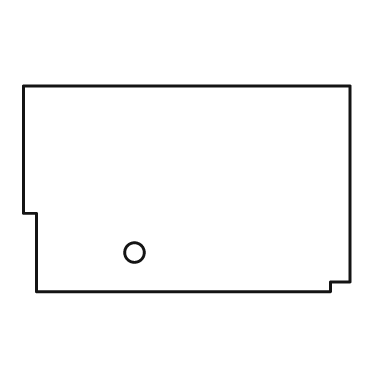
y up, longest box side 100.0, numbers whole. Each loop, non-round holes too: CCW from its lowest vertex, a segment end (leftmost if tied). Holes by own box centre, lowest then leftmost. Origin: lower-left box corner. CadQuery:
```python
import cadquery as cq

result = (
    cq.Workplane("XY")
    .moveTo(4.0, 0.0)
    .lineTo(94.0, 0.0)
    .lineTo(94.0, 3.0)
    .lineTo(100.0, 3.0)
    .lineTo(100.0, 63.0)
    .lineTo(0.0, 63.0)
    .lineTo(0.0, 24.0)
    .lineTo(4.0, 24.0)
    .close()
    .moveTo(34.0, 12.0)
    .circle(3.0)
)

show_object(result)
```